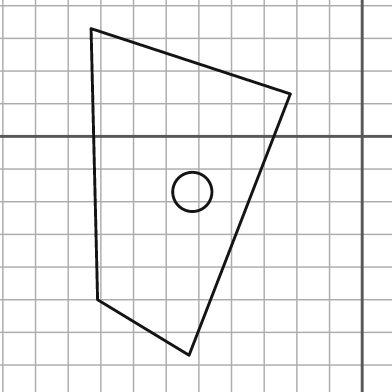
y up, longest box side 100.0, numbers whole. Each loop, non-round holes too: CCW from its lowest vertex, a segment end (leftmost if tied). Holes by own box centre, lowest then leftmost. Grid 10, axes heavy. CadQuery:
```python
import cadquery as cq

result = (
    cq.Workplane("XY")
    .moveTo(-53.0, -67.0)
    .lineTo(-22.0, 13.0)
    .lineTo(-83.0, 33.0)
    .lineTo(-81.0, -50.0)
    .close()
    .moveTo(-52.0, -17.0)
    .circle(6.0)
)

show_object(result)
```